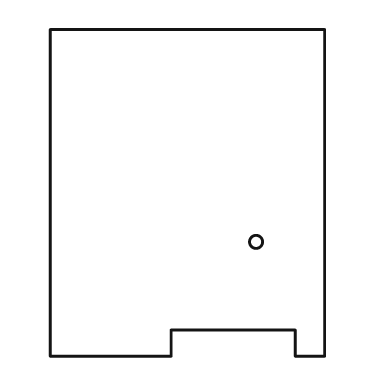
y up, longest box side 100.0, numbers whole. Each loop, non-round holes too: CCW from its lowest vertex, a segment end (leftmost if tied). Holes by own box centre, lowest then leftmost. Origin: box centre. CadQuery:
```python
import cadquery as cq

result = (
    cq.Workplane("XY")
    .moveTo(-42.0, -50.0)
    .lineTo(-5.0, -50.0)
    .lineTo(-5.0, -42.0)
    .lineTo(33.0, -42.0)
    .lineTo(33.0, -50.0)
    .lineTo(42.0, -50.0)
    .lineTo(42.0, 50.0)
    .lineTo(-42.0, 50.0)
    .close()
    .moveTo(21.0, -15.0)
    .circle(2.0)
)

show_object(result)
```